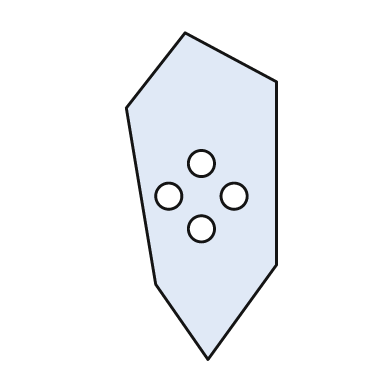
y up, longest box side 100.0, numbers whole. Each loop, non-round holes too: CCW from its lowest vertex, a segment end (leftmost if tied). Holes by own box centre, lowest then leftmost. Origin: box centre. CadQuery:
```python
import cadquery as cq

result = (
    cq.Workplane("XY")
    .moveTo(2.0, -50.0)
    .lineTo(23.0, -21.0)
    .lineTo(23.0, 35.0)
    .lineTo(-5.0, 50.0)
    .lineTo(-23.0, 27.0)
    .lineTo(-14.0, -27.0)
    .close()
    .moveTo(0.0, -10.0)
    .circle(4.0)
    .moveTo(-10.0, 0.0)
    .circle(4.0)
    .moveTo(10.0, 0.0)
    .circle(4.0)
    .moveTo(0.0, 10.0)
    .circle(4.0)
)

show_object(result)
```